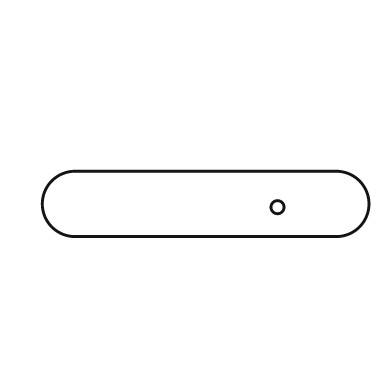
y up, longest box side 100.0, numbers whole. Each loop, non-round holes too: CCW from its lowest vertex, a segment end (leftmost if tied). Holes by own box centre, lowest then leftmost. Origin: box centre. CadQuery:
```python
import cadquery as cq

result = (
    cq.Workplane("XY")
    .moveTo(-40.0, -10.0)
    .lineTo(40.0, -10.0)
    .threePointArc((50.0, 0.0), (40.0, 10.0))
    .lineTo(-40.0, 10.0)
    .threePointArc((-50.0, 0.0), (-40.0, -10.0))
    .close()
    .moveTo(22.0, -1.0)
    .circle(2.0)
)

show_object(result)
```